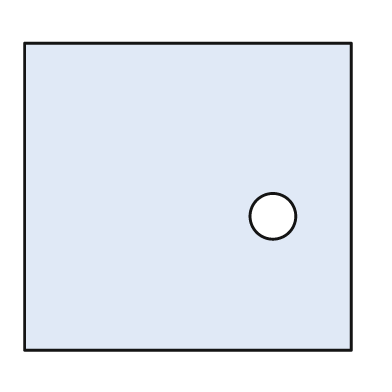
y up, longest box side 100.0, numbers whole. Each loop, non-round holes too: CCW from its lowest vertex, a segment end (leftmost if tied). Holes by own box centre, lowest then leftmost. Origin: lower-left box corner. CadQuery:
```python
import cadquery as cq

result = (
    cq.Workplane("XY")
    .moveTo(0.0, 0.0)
    .lineTo(100.0, 0.0)
    .lineTo(100.0, 94.0)
    .lineTo(0.0, 94.0)
    .close()
    .moveTo(76.0, 41.0)
    .circle(7.0)
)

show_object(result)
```